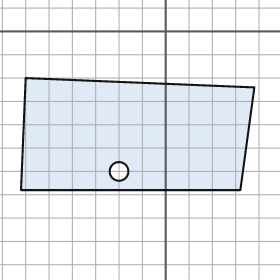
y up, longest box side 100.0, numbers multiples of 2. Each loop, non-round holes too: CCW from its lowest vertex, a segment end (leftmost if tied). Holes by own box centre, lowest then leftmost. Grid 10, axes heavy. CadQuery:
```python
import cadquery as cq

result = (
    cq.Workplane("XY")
    .moveTo(-62.0, -68.0)
    .lineTo(32.0, -68.0)
    .lineTo(38.0, -24.0)
    .lineTo(-60.0, -20.0)
    .close()
    .moveTo(-20.0, -60.0)
    .circle(4.0)
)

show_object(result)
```